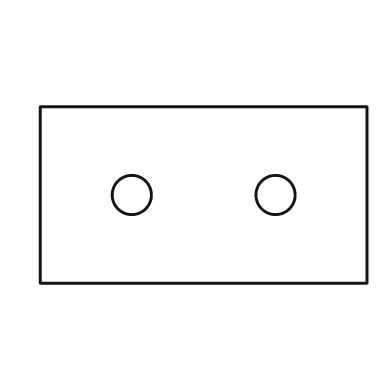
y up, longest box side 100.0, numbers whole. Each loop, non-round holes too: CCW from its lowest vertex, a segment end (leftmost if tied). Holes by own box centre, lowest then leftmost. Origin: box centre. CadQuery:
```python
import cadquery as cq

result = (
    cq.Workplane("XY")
    .moveTo(-50.0, -27.0)
    .lineTo(50.0, -27.0)
    .lineTo(50.0, 27.0)
    .lineTo(-50.0, 27.0)
    .close()
    .moveTo(-22.0, 0.0)
    .circle(6.0)
    .moveTo(22.0, 0.0)
    .circle(6.0)
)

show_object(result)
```